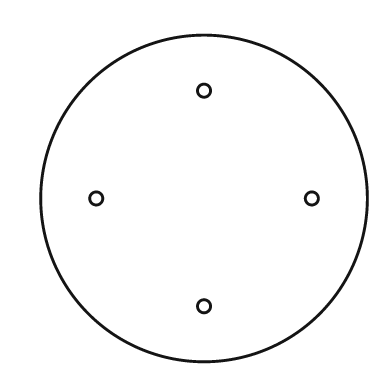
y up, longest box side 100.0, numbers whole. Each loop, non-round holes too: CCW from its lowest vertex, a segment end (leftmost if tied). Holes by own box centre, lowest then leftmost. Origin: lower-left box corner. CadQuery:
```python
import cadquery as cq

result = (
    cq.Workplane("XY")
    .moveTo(50.0, 50.0)
    .circle(50.0)
    .moveTo(50.0, 17.0)
    .circle(2.0)
    .moveTo(17.0, 50.0)
    .circle(2.0)
    .moveTo(83.0, 50.0)
    .circle(2.0)
    .moveTo(50.0, 83.0)
    .circle(2.0)
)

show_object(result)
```